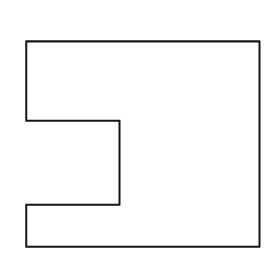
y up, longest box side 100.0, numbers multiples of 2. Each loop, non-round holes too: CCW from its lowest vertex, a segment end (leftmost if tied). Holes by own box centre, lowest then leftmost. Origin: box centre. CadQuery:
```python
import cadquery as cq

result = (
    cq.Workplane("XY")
    .moveTo(-50.0, -44.0)
    .lineTo(50.0, -44.0)
    .lineTo(50.0, 44.0)
    .lineTo(-50.0, 44.0)
    .lineTo(-50.0, 10.0)
    .lineTo(-10.0, 10.0)
    .lineTo(-10.0, -26.0)
    .lineTo(-50.0, -26.0)
    .close()
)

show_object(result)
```